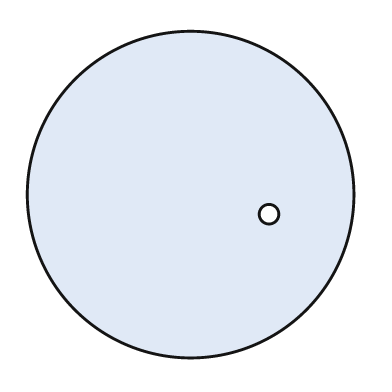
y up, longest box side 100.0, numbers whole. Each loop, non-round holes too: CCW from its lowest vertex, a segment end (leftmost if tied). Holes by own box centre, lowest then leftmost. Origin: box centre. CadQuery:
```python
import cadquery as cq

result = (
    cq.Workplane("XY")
    .moveTo(0.0, 0.0)
    .circle(50.0)
    .moveTo(24.0, -6.0)
    .circle(3.0)
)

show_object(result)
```